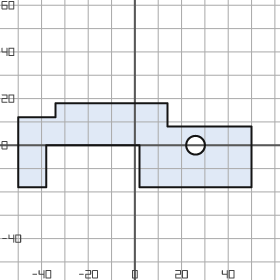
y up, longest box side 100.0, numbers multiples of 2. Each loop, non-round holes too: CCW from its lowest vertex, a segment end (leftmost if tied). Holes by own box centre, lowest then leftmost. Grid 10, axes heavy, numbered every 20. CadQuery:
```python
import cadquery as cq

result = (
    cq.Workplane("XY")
    .moveTo(-50.0, -18.0)
    .lineTo(-38.0, -18.0)
    .lineTo(-38.0, 0.0)
    .lineTo(2.0, 0.0)
    .lineTo(2.0, -18.0)
    .lineTo(50.0, -18.0)
    .lineTo(50.0, 8.0)
    .lineTo(14.0, 8.0)
    .lineTo(14.0, 18.0)
    .lineTo(-34.0, 18.0)
    .lineTo(-34.0, 12.0)
    .lineTo(-50.0, 12.0)
    .close()
    .moveTo(26.0, 0.0)
    .circle(4.0)
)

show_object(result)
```